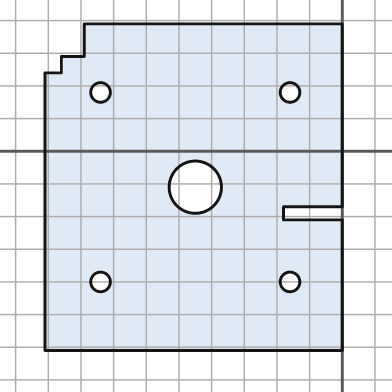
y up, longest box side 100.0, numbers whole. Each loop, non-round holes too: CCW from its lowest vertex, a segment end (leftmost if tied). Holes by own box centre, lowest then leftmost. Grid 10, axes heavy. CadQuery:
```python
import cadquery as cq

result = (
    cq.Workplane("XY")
    .moveTo(-91.0, -61.0)
    .lineTo(0.0, -61.0)
    .lineTo(0.0, -21.0)
    .lineTo(-18.0, -21.0)
    .lineTo(-18.0, -17.0)
    .lineTo(0.0, -17.0)
    .lineTo(0.0, 39.0)
    .lineTo(-79.0, 39.0)
    .lineTo(-79.0, 29.0)
    .lineTo(-86.0, 29.0)
    .lineTo(-86.0, 24.0)
    .lineTo(-91.0, 24.0)
    .close()
    .moveTo(-74.0, -40.0)
    .circle(3.0)
    .moveTo(-16.0, -40.0)
    .circle(3.0)
    .moveTo(-45.0, -11.0)
    .circle(8.0)
    .moveTo(-74.0, 18.0)
    .circle(3.0)
    .moveTo(-16.0, 18.0)
    .circle(3.0)
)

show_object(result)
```